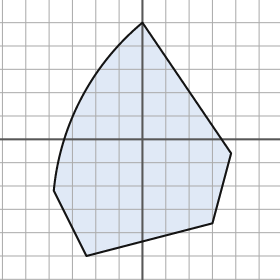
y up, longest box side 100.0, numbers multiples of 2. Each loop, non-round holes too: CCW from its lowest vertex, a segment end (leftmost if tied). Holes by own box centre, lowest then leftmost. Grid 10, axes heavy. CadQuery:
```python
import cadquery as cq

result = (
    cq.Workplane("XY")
    .moveTo(-24.0, -50.0)
    .lineTo(30.0, -36.0)
    .lineTo(38.0, -6.0)
    .lineTo(0.0, 50.0)
    .threePointArc((-26.0, 18.0), (-38.0, -22.0))
    .close()
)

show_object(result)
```